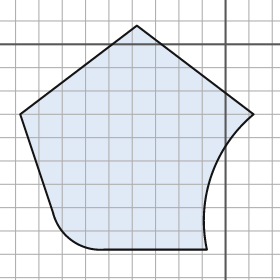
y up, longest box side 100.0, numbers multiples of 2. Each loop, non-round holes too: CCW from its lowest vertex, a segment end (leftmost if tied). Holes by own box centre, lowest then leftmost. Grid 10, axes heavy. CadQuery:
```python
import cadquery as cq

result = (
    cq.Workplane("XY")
    .moveTo(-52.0, -88.0)
    .lineTo(-8.0, -88.0)
    .threePointArc((-6.0, -56.0), (12.0, -30.0))
    .lineTo(-38.0, 8.0)
    .lineTo(-88.0, -30.0)
    .lineTo(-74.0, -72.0)
    .threePointArc((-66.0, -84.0), (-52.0, -88.0))
    .close()
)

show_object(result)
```